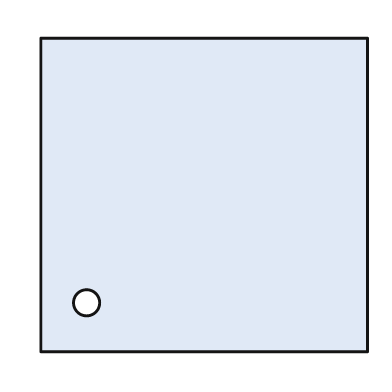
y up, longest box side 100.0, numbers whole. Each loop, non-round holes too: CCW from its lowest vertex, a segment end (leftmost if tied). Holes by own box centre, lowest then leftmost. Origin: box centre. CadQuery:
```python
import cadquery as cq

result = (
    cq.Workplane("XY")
    .moveTo(-50.0, -48.0)
    .lineTo(50.0, -48.0)
    .lineTo(50.0, 48.0)
    .lineTo(-50.0, 48.0)
    .close()
    .moveTo(-36.0, -33.0)
    .circle(4.0)
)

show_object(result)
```